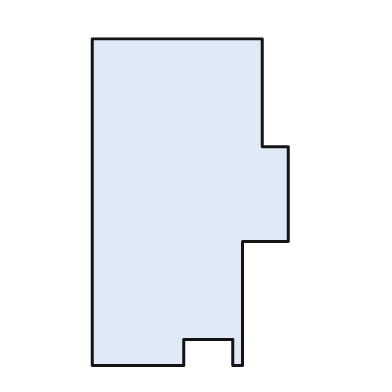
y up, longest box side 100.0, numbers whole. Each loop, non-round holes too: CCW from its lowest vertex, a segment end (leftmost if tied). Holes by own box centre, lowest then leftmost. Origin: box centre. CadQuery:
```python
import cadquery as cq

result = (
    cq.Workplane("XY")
    .moveTo(-30.0, -50.0)
    .lineTo(-2.0, -50.0)
    .lineTo(-2.0, -42.0)
    .lineTo(13.0, -42.0)
    .lineTo(13.0, -50.0)
    .lineTo(16.0, -50.0)
    .lineTo(16.0, -12.0)
    .lineTo(30.0, -12.0)
    .lineTo(30.0, 17.0)
    .lineTo(22.0, 17.0)
    .lineTo(22.0, 50.0)
    .lineTo(-30.0, 50.0)
    .close()
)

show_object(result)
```